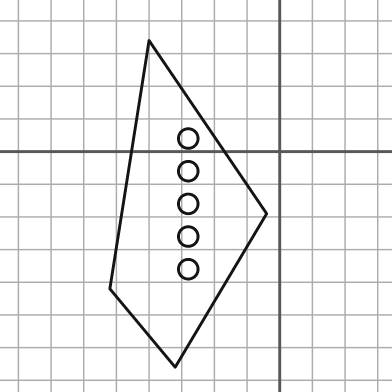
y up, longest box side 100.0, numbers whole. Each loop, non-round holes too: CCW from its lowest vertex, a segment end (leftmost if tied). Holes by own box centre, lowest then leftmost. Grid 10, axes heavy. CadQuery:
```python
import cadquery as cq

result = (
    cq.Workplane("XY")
    .moveTo(-32.0, -66.0)
    .lineTo(-4.0, -19.0)
    .lineTo(-40.0, 34.0)
    .lineTo(-52.0, -42.0)
    .close()
    .moveTo(-28.0, -36.0)
    .circle(3.0)
    .moveTo(-28.0, -26.0)
    .circle(3.0)
    .moveTo(-28.0, -16.0)
    .circle(3.0)
    .moveTo(-28.0, -6.0)
    .circle(3.0)
    .moveTo(-28.0, 4.0)
    .circle(3.0)
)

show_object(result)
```